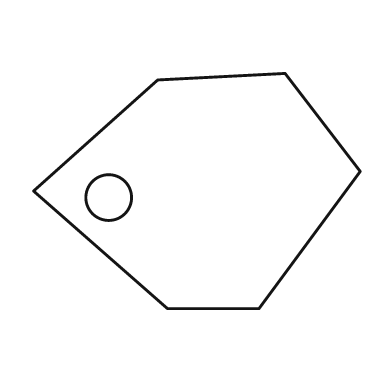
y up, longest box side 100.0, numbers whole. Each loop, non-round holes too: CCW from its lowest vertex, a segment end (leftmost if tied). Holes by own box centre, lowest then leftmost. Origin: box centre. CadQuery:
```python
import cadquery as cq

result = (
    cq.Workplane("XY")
    .moveTo(-9.0, -36.0)
    .lineTo(19.0, -36.0)
    .lineTo(50.0, 6.0)
    .lineTo(27.0, 36.0)
    .lineTo(-12.0, 34.0)
    .lineTo(-50.0, 0.0)
    .close()
    .moveTo(-27.0, -2.0)
    .circle(7.0)
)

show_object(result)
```